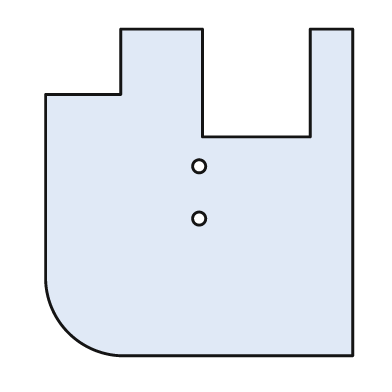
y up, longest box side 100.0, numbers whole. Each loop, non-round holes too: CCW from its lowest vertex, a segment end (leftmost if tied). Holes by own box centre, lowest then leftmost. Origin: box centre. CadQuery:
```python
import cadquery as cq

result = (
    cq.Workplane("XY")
    .moveTo(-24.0, -50.0)
    .lineTo(47.0, -50.0)
    .lineTo(47.0, 50.0)
    .lineTo(34.0, 50.0)
    .lineTo(34.0, 17.0)
    .lineTo(1.0, 17.0)
    .lineTo(1.0, 50.0)
    .lineTo(-24.0, 50.0)
    .lineTo(-24.0, 30.0)
    .lineTo(-47.0, 30.0)
    .lineTo(-47.0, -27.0)
    .threePointArc((-40.0, -43.0), (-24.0, -50.0))
    .close()
    .moveTo(0.0, -8.0)
    .circle(2.0)
    .moveTo(0.0, 8.0)
    .circle(2.0)
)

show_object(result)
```